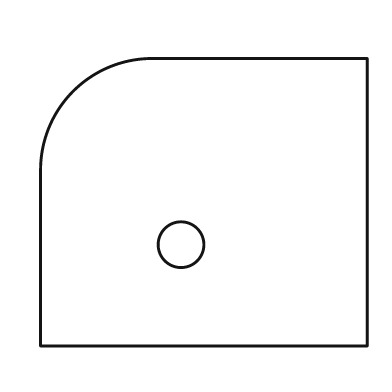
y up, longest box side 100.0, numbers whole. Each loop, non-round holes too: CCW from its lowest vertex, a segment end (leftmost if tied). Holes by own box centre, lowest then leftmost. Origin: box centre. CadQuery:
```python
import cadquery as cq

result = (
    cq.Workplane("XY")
    .moveTo(-50.0, -44.0)
    .lineTo(50.0, -44.0)
    .lineTo(50.0, 44.0)
    .lineTo(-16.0, 44.0)
    .threePointArc((-40.0, 34.0), (-50.0, 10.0))
    .close()
    .moveTo(-7.0, -13.0)
    .circle(7.0)
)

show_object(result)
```